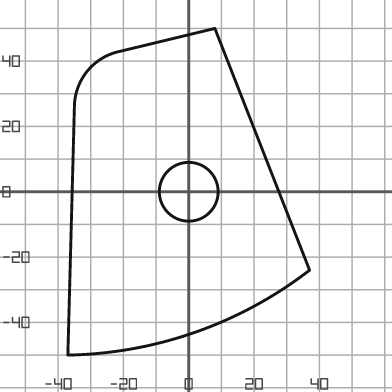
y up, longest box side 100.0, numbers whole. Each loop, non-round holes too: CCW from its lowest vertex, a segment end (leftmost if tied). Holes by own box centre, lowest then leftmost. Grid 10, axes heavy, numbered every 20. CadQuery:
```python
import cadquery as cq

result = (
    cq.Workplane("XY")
    .moveTo(-37.0, -50.0)
    .threePointArc((2.0, -43.0), (37.0, -24.0))
    .lineTo(8.0, 50.0)
    .lineTo(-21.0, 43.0)
    .threePointArc((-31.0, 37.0), (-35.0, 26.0))
    .close()
    .moveTo(0.0, 0.0)
    .circle(9.0)
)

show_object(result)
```